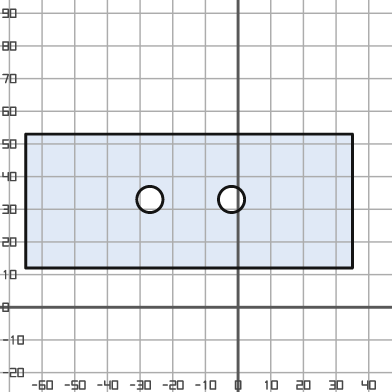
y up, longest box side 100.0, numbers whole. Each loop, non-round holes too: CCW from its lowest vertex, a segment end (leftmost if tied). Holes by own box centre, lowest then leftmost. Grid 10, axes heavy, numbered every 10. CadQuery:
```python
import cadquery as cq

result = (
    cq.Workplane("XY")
    .moveTo(-65.0, 12.0)
    .lineTo(35.0, 12.0)
    .lineTo(35.0, 53.0)
    .lineTo(-65.0, 53.0)
    .close()
    .moveTo(-27.0, 33.0)
    .circle(4.0)
    .moveTo(-2.0, 33.0)
    .circle(4.0)
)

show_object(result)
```